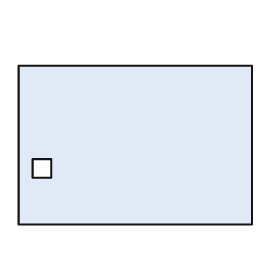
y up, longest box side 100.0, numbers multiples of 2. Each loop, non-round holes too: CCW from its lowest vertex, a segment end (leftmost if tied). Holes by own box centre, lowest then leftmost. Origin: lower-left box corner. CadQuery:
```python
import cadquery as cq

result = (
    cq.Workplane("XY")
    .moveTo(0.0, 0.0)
    .lineTo(100.0, 0.0)
    .lineTo(100.0, 68.0)
    .lineTo(0.0, 68.0)
    .close()
    .moveTo(6.0, 20.0)
    .lineTo(14.0, 20.0)
    .lineTo(14.0, 28.0)
    .lineTo(6.0, 28.0)
    .close()
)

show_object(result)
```